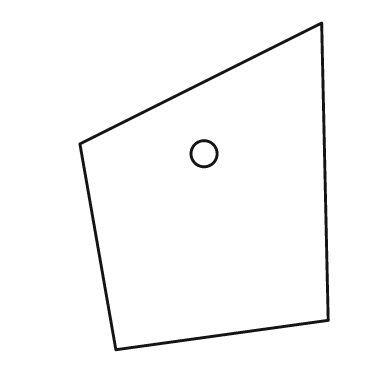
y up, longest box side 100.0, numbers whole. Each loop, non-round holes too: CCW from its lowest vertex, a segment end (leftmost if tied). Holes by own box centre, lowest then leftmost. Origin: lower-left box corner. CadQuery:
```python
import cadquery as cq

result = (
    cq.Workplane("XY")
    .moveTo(11.0, 0.0)
    .lineTo(76.0, 9.0)
    .lineTo(74.0, 100.0)
    .lineTo(0.0, 63.0)
    .close()
    .moveTo(38.0, 60.0)
    .circle(4.0)
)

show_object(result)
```